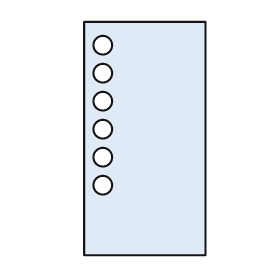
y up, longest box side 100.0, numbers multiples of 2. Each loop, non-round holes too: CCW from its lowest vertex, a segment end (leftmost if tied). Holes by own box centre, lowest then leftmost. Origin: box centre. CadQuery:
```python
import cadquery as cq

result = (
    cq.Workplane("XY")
    .moveTo(-26.0, -50.0)
    .lineTo(26.0, -50.0)
    .lineTo(26.0, 50.0)
    .lineTo(-26.0, 50.0)
    .close()
    .moveTo(-18.0, -20.0)
    .circle(4.0)
    .moveTo(-18.0, -8.0)
    .circle(4.0)
    .moveTo(-18.0, 4.0)
    .circle(4.0)
    .moveTo(-18.0, 16.0)
    .circle(4.0)
    .moveTo(-18.0, 28.0)
    .circle(4.0)
    .moveTo(-18.0, 40.0)
    .circle(4.0)
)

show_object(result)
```